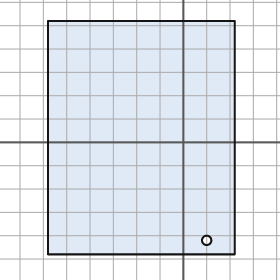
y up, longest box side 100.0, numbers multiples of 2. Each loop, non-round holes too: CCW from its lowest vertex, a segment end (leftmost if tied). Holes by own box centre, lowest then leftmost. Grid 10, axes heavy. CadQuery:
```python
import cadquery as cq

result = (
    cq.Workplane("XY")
    .moveTo(-58.0, -48.0)
    .lineTo(22.0, -48.0)
    .lineTo(22.0, 52.0)
    .lineTo(-58.0, 52.0)
    .close()
    .moveTo(10.0, -42.0)
    .circle(2.0)
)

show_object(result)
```